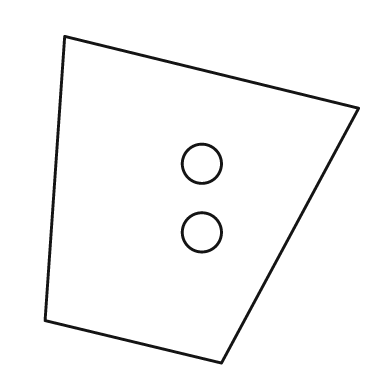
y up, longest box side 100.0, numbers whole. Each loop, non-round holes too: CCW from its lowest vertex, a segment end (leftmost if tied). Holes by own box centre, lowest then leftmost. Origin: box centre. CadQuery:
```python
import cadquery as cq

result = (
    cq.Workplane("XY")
    .moveTo(6.0, -50.0)
    .lineTo(48.0, 28.0)
    .lineTo(-42.0, 50.0)
    .lineTo(-48.0, -37.0)
    .close()
    .moveTo(0.0, -10.0)
    .circle(6.0)
    .moveTo(0.0, 11.0)
    .circle(6.0)
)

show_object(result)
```